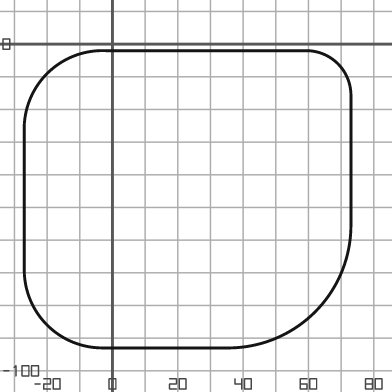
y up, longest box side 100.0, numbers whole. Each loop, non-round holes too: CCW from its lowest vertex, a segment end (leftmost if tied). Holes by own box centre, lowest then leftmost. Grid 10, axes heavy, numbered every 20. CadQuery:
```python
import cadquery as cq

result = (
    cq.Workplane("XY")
    .moveTo(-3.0, -93.0)
    .lineTo(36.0, -93.0)
    .threePointArc((62.0, -82.0), (73.0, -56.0))
    .lineTo(73.0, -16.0)
    .threePointArc((69.0, -6.0), (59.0, -2.0))
    .lineTo(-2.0, -2.0)
    .threePointArc((-20.0, -9.0), (-27.0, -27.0))
    .lineTo(-27.0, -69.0)
    .threePointArc((-20.0, -86.0), (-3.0, -93.0))
    .close()
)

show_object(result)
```